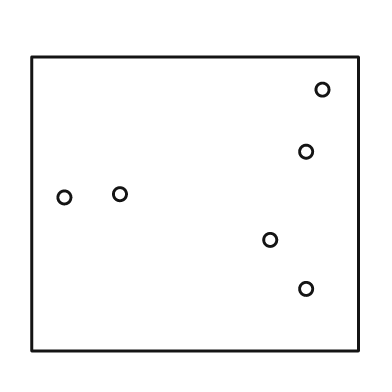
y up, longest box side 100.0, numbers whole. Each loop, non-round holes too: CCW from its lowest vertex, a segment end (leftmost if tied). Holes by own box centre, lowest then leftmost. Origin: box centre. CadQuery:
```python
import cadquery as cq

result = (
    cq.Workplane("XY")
    .moveTo(-50.0, -45.0)
    .lineTo(50.0, -45.0)
    .lineTo(50.0, 45.0)
    .lineTo(-50.0, 45.0)
    .close()
    .moveTo(34.0, -26.0)
    .circle(2.0)
    .moveTo(23.0, -11.0)
    .circle(2.0)
    .moveTo(-40.0, 2.0)
    .circle(2.0)
    .moveTo(-23.0, 3.0)
    .circle(2.0)
    .moveTo(34.0, 16.0)
    .circle(2.0)
    .moveTo(39.0, 35.0)
    .circle(2.0)
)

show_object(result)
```